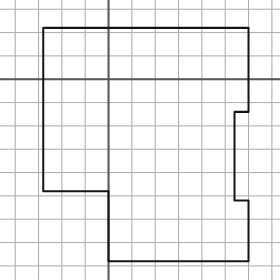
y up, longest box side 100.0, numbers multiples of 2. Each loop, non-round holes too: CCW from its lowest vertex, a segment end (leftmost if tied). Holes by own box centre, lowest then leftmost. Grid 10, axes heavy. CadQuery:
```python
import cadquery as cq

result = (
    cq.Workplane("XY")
    .moveTo(0.0, -78.0)
    .lineTo(60.0, -78.0)
    .lineTo(60.0, -52.0)
    .lineTo(54.0, -52.0)
    .lineTo(54.0, -14.0)
    .lineTo(60.0, -14.0)
    .lineTo(60.0, 22.0)
    .lineTo(-28.0, 22.0)
    .lineTo(-28.0, -48.0)
    .lineTo(0.0, -48.0)
    .close()
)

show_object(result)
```